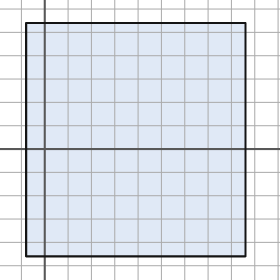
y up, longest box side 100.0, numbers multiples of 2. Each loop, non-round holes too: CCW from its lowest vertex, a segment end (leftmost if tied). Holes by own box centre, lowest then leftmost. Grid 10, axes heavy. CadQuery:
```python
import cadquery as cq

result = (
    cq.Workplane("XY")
    .moveTo(-8.0, -46.0)
    .lineTo(86.0, -46.0)
    .lineTo(86.0, 54.0)
    .lineTo(-8.0, 54.0)
    .close()
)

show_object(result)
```